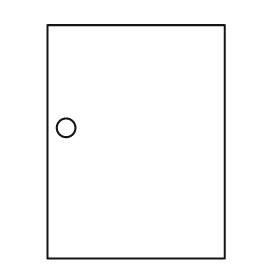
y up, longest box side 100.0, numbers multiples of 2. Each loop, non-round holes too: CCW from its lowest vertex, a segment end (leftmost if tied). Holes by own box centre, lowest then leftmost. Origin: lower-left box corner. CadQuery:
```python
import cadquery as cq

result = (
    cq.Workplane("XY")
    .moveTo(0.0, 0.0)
    .lineTo(76.0, 0.0)
    .lineTo(76.0, 100.0)
    .lineTo(0.0, 100.0)
    .close()
    .moveTo(8.0, 56.0)
    .circle(4.0)
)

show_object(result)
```